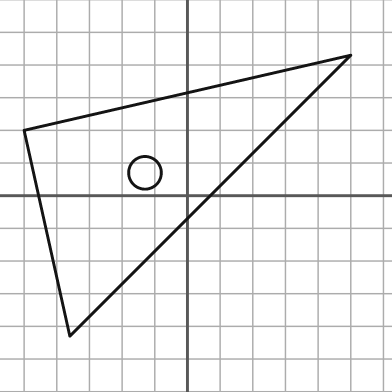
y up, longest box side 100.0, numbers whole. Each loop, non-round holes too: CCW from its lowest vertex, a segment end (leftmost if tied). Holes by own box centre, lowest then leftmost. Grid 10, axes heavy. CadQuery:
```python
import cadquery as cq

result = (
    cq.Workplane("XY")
    .moveTo(-36.0, -43.0)
    .lineTo(50.0, 43.0)
    .lineTo(-50.0, 20.0)
    .close()
    .moveTo(-13.0, 7.0)
    .circle(5.0)
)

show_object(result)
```